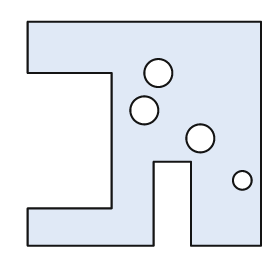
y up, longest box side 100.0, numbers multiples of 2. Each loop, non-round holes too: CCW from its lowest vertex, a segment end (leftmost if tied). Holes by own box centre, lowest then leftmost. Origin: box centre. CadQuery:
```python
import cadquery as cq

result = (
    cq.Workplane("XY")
    .moveTo(-50.0, -48.0)
    .lineTo(4.0, -48.0)
    .lineTo(4.0, -12.0)
    .lineTo(20.0, -12.0)
    .lineTo(20.0, -48.0)
    .lineTo(50.0, -48.0)
    .lineTo(50.0, 48.0)
    .lineTo(-50.0, 48.0)
    .lineTo(-50.0, 26.0)
    .lineTo(-14.0, 26.0)
    .lineTo(-14.0, -32.0)
    .lineTo(-50.0, -32.0)
    .close()
    .moveTo(42.0, -20.0)
    .circle(4.0)
    .moveTo(24.0, -2.0)
    .circle(6.0)
    .moveTo(0.0, 10.0)
    .circle(6.0)
    .moveTo(6.0, 26.0)
    .circle(6.0)
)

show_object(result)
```